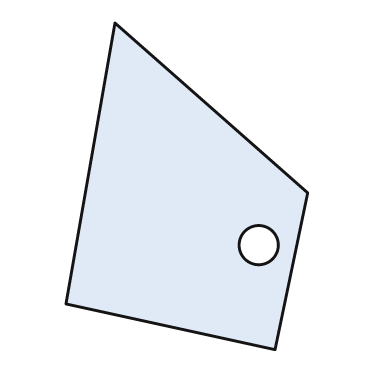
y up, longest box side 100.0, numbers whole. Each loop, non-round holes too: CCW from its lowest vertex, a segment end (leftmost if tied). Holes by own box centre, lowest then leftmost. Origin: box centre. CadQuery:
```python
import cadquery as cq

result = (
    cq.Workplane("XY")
    .moveTo(27.0, -50.0)
    .lineTo(37.0, -2.0)
    .lineTo(-22.0, 50.0)
    .lineTo(-37.0, -36.0)
    .close()
    .moveTo(22.0, -18.0)
    .circle(6.0)
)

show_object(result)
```